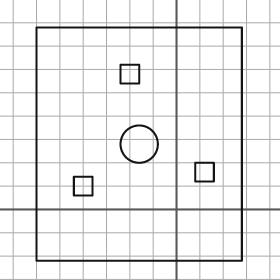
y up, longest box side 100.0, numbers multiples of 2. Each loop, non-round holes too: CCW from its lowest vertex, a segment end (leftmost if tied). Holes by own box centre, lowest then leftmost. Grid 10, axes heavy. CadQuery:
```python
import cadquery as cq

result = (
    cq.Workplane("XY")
    .moveTo(-60.0, -22.0)
    .lineTo(28.0, -22.0)
    .lineTo(28.0, 78.0)
    .lineTo(-60.0, 78.0)
    .close()
    .moveTo(-44.0, 6.0)
    .lineTo(-36.0, 6.0)
    .lineTo(-36.0, 14.0)
    .lineTo(-44.0, 14.0)
    .close()
    .moveTo(8.0, 12.0)
    .lineTo(16.0, 12.0)
    .lineTo(16.0, 20.0)
    .lineTo(8.0, 20.0)
    .close()
    .moveTo(-16.0, 28.0)
    .circle(8.0)
    .moveTo(-24.0, 54.0)
    .lineTo(-16.0, 54.0)
    .lineTo(-16.0, 62.0)
    .lineTo(-24.0, 62.0)
    .close()
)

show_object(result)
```